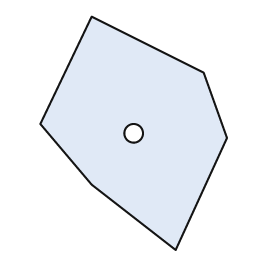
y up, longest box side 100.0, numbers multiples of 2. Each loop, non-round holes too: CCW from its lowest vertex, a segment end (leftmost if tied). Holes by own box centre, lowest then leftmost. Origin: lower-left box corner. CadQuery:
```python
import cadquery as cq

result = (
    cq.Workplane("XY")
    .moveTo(58.0, 0.0)
    .lineTo(80.0, 48.0)
    .lineTo(70.0, 76.0)
    .lineTo(22.0, 100.0)
    .lineTo(0.0, 54.0)
    .lineTo(22.0, 28.0)
    .close()
    .moveTo(40.0, 50.0)
    .circle(4.0)
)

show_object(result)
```